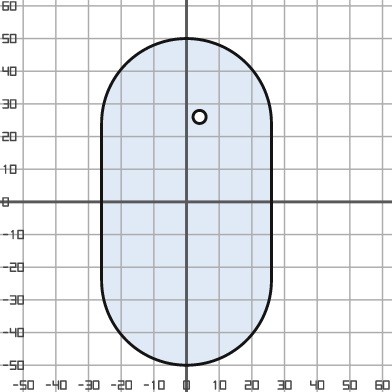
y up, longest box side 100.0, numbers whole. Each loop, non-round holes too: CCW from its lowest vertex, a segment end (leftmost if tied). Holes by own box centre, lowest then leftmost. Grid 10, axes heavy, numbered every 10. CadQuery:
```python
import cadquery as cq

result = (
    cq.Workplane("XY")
    .moveTo(-26.0, -24.0)
    .threePointArc((0.0, -50.0), (26.0, -24.0))
    .lineTo(26.0, 24.0)
    .threePointArc((0.0, 50.0), (-26.0, 24.0))
    .close()
    .moveTo(4.0, 26.0)
    .circle(2.0)
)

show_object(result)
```